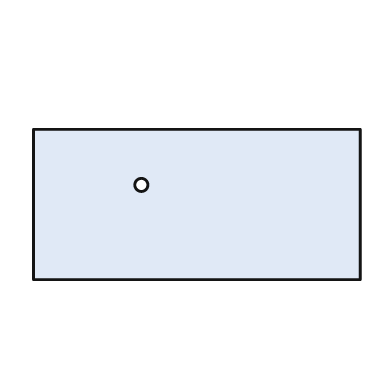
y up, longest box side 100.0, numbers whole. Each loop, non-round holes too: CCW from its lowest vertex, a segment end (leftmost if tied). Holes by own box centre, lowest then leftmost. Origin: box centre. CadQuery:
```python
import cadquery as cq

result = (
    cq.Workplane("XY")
    .moveTo(-50.0, -23.0)
    .lineTo(50.0, -23.0)
    .lineTo(50.0, 23.0)
    .lineTo(-50.0, 23.0)
    .close()
    .moveTo(-17.0, 6.0)
    .circle(2.0)
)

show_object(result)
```